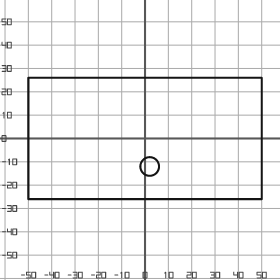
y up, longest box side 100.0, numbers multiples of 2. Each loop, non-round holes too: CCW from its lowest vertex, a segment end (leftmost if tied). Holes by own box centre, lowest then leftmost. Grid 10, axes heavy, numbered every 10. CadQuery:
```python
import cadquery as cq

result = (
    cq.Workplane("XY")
    .moveTo(-50.0, -26.0)
    .lineTo(50.0, -26.0)
    .lineTo(50.0, 26.0)
    .lineTo(-50.0, 26.0)
    .close()
    .moveTo(2.0, -12.0)
    .circle(4.0)
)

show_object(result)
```